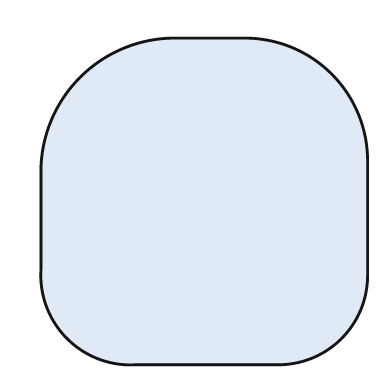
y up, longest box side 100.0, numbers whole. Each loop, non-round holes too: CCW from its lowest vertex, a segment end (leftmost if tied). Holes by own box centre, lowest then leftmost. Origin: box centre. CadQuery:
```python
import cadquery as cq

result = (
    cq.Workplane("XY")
    .moveTo(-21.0, -50.0)
    .lineTo(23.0, -50.0)
    .threePointArc((42.0, -42.0), (50.0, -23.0))
    .lineTo(50.0, 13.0)
    .threePointArc((39.0, 39.0), (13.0, 50.0))
    .lineTo(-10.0, 50.0)
    .threePointArc((-38.0, 38.0), (-50.0, 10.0))
    .lineTo(-50.0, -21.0)
    .threePointArc((-42.0, -42.0), (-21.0, -50.0))
    .close()
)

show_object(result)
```